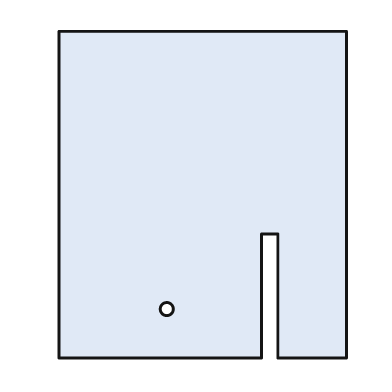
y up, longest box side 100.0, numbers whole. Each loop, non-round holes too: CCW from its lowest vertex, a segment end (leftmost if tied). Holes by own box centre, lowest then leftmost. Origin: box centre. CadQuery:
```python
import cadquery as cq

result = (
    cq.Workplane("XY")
    .moveTo(-44.0, -50.0)
    .lineTo(18.0, -50.0)
    .lineTo(18.0, -12.0)
    .lineTo(23.0, -12.0)
    .lineTo(23.0, -50.0)
    .lineTo(44.0, -50.0)
    .lineTo(44.0, 50.0)
    .lineTo(-44.0, 50.0)
    .close()
    .moveTo(-11.0, -35.0)
    .circle(2.0)
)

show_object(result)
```